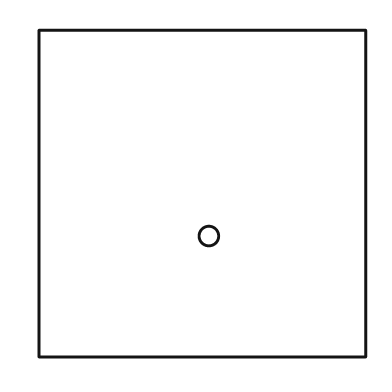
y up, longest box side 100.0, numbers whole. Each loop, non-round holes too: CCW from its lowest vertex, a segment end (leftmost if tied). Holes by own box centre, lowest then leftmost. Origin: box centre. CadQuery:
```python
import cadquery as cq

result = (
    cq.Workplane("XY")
    .moveTo(-50.0, -50.0)
    .lineTo(50.0, -50.0)
    .lineTo(50.0, 50.0)
    .lineTo(-50.0, 50.0)
    .close()
    .moveTo(2.0, -13.0)
    .circle(3.0)
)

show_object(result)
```